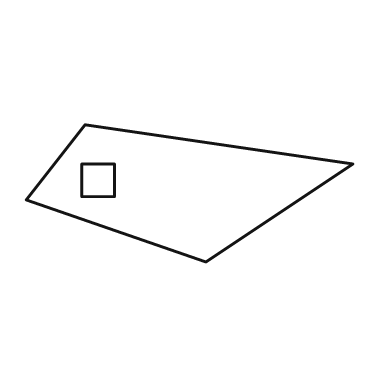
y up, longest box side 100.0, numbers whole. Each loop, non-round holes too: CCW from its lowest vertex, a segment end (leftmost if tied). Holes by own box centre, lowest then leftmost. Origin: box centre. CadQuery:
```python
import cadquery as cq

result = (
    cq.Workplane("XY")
    .moveTo(5.0, -21.0)
    .lineTo(50.0, 9.0)
    .lineTo(-32.0, 21.0)
    .lineTo(-50.0, -2.0)
    .close()
    .moveTo(-33.0, -1.0)
    .lineTo(-23.0, -1.0)
    .lineTo(-23.0, 9.0)
    .lineTo(-33.0, 9.0)
    .close()
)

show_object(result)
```